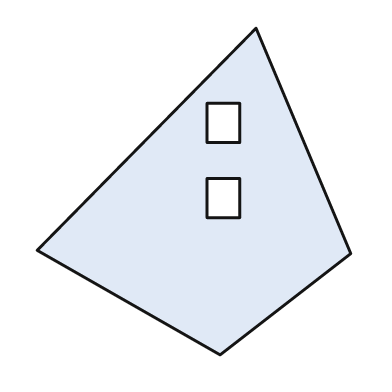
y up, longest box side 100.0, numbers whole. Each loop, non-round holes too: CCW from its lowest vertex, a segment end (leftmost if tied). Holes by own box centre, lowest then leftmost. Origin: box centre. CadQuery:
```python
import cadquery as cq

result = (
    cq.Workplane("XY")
    .moveTo(8.0, -50.0)
    .lineTo(48.0, -19.0)
    .lineTo(19.0, 50.0)
    .lineTo(-48.0, -18.0)
    .close()
    .moveTo(4.0, -8.0)
    .lineTo(14.0, -8.0)
    .lineTo(14.0, 4.0)
    .lineTo(4.0, 4.0)
    .close()
    .moveTo(4.0, 15.0)
    .lineTo(14.0, 15.0)
    .lineTo(14.0, 27.0)
    .lineTo(4.0, 27.0)
    .close()
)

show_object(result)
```